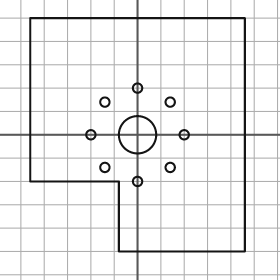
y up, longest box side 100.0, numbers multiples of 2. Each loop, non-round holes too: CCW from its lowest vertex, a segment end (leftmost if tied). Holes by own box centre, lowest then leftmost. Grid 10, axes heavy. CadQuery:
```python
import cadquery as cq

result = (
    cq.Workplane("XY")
    .moveTo(-8.0, -50.0)
    .lineTo(46.0, -50.0)
    .lineTo(46.0, 50.0)
    .lineTo(-46.0, 50.0)
    .lineTo(-46.0, -20.0)
    .lineTo(-8.0, -20.0)
    .close()
    .moveTo(0.0, -20.0)
    .circle(2.0)
    .moveTo(-14.0, -14.0)
    .circle(2.0)
    .moveTo(14.0, -14.0)
    .circle(2.0)
    .moveTo(-20.0, 0.0)
    .circle(2.0)
    .moveTo(0.0, 0.0)
    .circle(8.0)
    .moveTo(20.0, 0.0)
    .circle(2.0)
    .moveTo(-14.0, 14.0)
    .circle(2.0)
    .moveTo(14.0, 14.0)
    .circle(2.0)
    .moveTo(0.0, 20.0)
    .circle(2.0)
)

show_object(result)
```